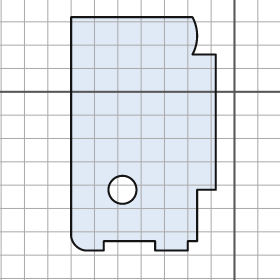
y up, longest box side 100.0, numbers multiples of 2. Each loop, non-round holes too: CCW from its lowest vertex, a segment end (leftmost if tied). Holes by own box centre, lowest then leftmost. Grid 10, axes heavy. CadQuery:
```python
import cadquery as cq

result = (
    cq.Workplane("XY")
    .moveTo(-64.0, -68.0)
    .lineTo(-56.0, -68.0)
    .lineTo(-56.0, -64.0)
    .lineTo(-34.0, -64.0)
    .lineTo(-34.0, -68.0)
    .lineTo(-20.0, -68.0)
    .lineTo(-20.0, -64.0)
    .lineTo(-16.0, -64.0)
    .lineTo(-16.0, -42.0)
    .lineTo(-8.0, -42.0)
    .lineTo(-8.0, 16.0)
    .lineTo(-18.0, 16.0)
    .threePointArc((-16.0, 24.0), (-18.0, 32.0))
    .lineTo(-70.0, 32.0)
    .lineTo(-70.0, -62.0)
    .threePointArc((-68.0, -66.0), (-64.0, -68.0))
    .close()
    .moveTo(-48.0, -42.0)
    .circle(6.0)
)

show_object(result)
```